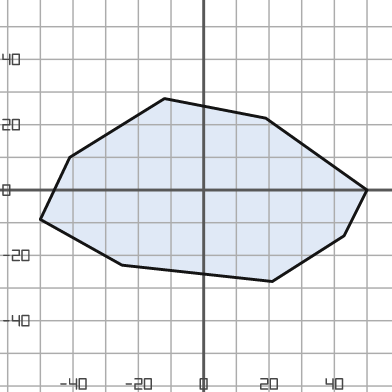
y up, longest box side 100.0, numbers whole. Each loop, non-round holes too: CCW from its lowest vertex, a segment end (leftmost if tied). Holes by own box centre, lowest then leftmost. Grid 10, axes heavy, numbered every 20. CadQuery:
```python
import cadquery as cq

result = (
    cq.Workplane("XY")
    .moveTo(21.0, -28.0)
    .lineTo(43.0, -14.0)
    .lineTo(50.0, 0.0)
    .lineTo(19.0, 22.0)
    .lineTo(-12.0, 28.0)
    .lineTo(-41.0, 10.0)
    .lineTo(-50.0, -9.0)
    .lineTo(-25.0, -23.0)
    .close()
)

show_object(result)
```